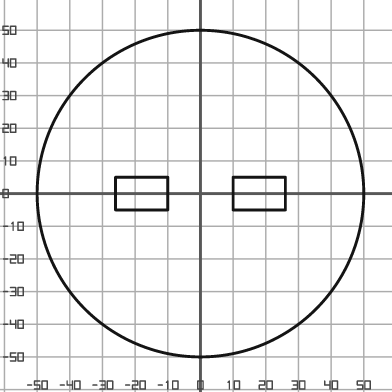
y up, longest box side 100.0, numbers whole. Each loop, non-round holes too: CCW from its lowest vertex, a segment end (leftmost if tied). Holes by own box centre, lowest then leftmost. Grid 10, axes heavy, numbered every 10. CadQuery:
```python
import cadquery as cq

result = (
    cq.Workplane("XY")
    .moveTo(0.0, 0.0)
    .circle(50.0)
    .moveTo(-26.0, -5.0)
    .lineTo(-10.0, -5.0)
    .lineTo(-10.0, 5.0)
    .lineTo(-26.0, 5.0)
    .close()
    .moveTo(10.0, -5.0)
    .lineTo(26.0, -5.0)
    .lineTo(26.0, 5.0)
    .lineTo(10.0, 5.0)
    .close()
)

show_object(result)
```